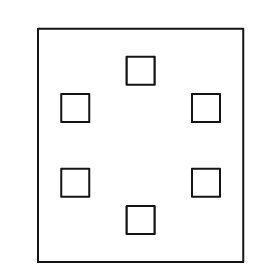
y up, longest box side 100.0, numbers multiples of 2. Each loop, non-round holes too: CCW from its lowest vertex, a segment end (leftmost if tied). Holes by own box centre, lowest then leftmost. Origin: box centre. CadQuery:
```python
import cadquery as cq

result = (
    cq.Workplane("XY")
    .moveTo(-44.0, -50.0)
    .lineTo(44.0, -50.0)
    .lineTo(44.0, 50.0)
    .lineTo(-44.0, 50.0)
    .close()
    .moveTo(-6.0, -38.0)
    .lineTo(6.0, -38.0)
    .lineTo(6.0, -26.0)
    .lineTo(-6.0, -26.0)
    .close()
    .moveTo(-34.0, -22.0)
    .lineTo(-22.0, -22.0)
    .lineTo(-22.0, -10.0)
    .lineTo(-34.0, -10.0)
    .close()
    .moveTo(22.0, -22.0)
    .lineTo(34.0, -22.0)
    .lineTo(34.0, -10.0)
    .lineTo(22.0, -10.0)
    .close()
    .moveTo(-34.0, 10.0)
    .lineTo(-22.0, 10.0)
    .lineTo(-22.0, 22.0)
    .lineTo(-34.0, 22.0)
    .close()
    .moveTo(22.0, 10.0)
    .lineTo(34.0, 10.0)
    .lineTo(34.0, 22.0)
    .lineTo(22.0, 22.0)
    .close()
    .moveTo(-6.0, 26.0)
    .lineTo(6.0, 26.0)
    .lineTo(6.0, 38.0)
    .lineTo(-6.0, 38.0)
    .close()
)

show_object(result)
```